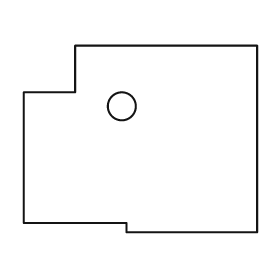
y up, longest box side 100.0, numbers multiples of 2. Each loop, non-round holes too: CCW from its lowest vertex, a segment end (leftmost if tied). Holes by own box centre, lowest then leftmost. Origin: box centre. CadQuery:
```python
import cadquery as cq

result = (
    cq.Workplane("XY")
    .moveTo(-6.0, -40.0)
    .lineTo(50.0, -40.0)
    .lineTo(50.0, 40.0)
    .lineTo(-28.0, 40.0)
    .lineTo(-28.0, 20.0)
    .lineTo(-50.0, 20.0)
    .lineTo(-50.0, -36.0)
    .lineTo(-6.0, -36.0)
    .close()
    .moveTo(-8.0, 14.0)
    .circle(6.0)
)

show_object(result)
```